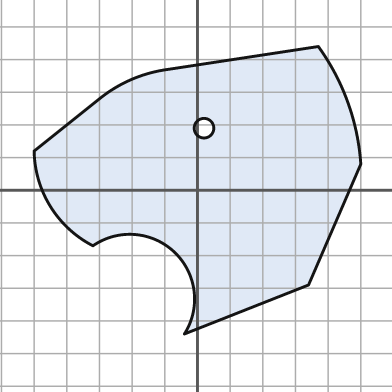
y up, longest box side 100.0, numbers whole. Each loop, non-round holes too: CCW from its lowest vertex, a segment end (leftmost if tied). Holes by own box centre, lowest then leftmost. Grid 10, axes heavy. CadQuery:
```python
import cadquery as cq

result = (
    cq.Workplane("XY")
    .moveTo(-4.0, -44.0)
    .lineTo(34.0, -29.0)
    .lineTo(50.0, 8.0)
    .threePointArc((46.0, 27.0), (37.0, 44.0))
    .lineTo(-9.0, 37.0)
    .threePointArc((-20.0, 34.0), (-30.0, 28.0))
    .lineTo(-50.0, 12.0)
    .threePointArc((-45.0, -5.0), (-32.0, -17.0))
    .threePointArc((-7.0, -19.0), (-4.0, -44.0))
    .close()
    .moveTo(2.0, 19.0)
    .circle(3.0)
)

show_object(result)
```